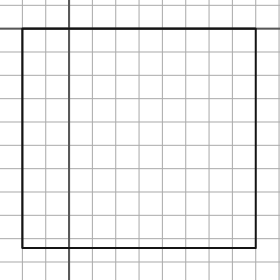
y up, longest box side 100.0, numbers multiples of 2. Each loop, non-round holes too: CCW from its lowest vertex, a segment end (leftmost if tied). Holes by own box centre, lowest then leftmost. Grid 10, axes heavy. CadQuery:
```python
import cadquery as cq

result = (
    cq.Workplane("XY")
    .moveTo(-20.0, -94.0)
    .lineTo(80.0, -94.0)
    .lineTo(80.0, 0.0)
    .lineTo(-20.0, 0.0)
    .close()
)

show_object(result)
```